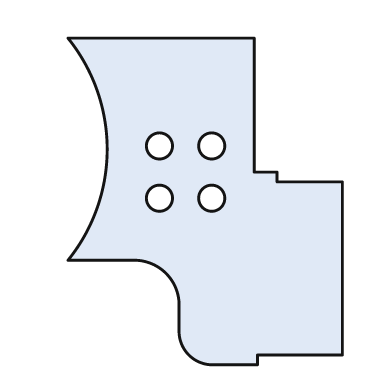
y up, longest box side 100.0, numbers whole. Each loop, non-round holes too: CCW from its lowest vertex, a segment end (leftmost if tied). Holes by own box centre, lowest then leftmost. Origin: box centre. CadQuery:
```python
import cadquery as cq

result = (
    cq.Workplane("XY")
    .moveTo(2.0, -50.0)
    .lineTo(16.0, -50.0)
    .lineTo(16.0, -47.0)
    .lineTo(42.0, -47.0)
    .lineTo(42.0, 6.0)
    .lineTo(22.0, 6.0)
    .lineTo(22.0, 9.0)
    .lineTo(15.0, 9.0)
    .lineTo(15.0, 50.0)
    .lineTo(-42.0, 50.0)
    .threePointArc((-30.0, 16.0), (-42.0, -18.0))
    .lineTo(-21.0, -18.0)
    .threePointArc((-12.0, -22.0), (-8.0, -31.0))
    .lineTo(-8.0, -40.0)
    .threePointArc((-5.0, -47.0), (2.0, -50.0))
    .close()
    .moveTo(-14.0, 1.0)
    .circle(4.0)
    .moveTo(2.0, 1.0)
    .circle(4.0)
    .moveTo(-14.0, 17.0)
    .circle(4.0)
    .moveTo(2.0, 17.0)
    .circle(4.0)
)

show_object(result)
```